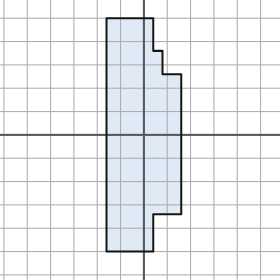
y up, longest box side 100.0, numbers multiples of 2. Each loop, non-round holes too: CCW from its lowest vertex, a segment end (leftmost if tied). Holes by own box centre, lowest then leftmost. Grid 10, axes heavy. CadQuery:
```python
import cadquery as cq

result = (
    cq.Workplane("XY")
    .moveTo(-16.0, -50.0)
    .lineTo(4.0, -50.0)
    .lineTo(4.0, -34.0)
    .lineTo(16.0, -34.0)
    .lineTo(16.0, 26.0)
    .lineTo(8.0, 26.0)
    .lineTo(8.0, 36.0)
    .lineTo(4.0, 36.0)
    .lineTo(4.0, 50.0)
    .lineTo(-16.0, 50.0)
    .close()
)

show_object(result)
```